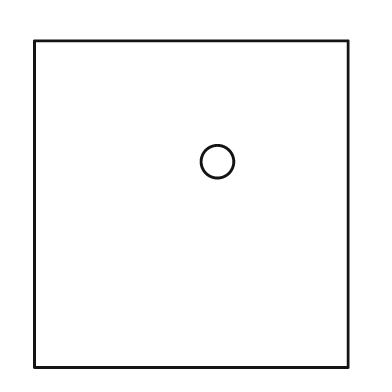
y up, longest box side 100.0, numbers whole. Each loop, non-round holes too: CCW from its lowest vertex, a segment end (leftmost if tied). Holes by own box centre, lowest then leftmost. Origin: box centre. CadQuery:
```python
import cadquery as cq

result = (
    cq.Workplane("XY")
    .moveTo(-48.0, -50.0)
    .lineTo(48.0, -50.0)
    .lineTo(48.0, 50.0)
    .lineTo(-48.0, 50.0)
    .close()
    .moveTo(8.0, 13.0)
    .circle(5.0)
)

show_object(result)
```